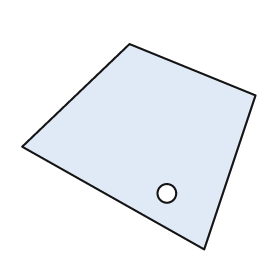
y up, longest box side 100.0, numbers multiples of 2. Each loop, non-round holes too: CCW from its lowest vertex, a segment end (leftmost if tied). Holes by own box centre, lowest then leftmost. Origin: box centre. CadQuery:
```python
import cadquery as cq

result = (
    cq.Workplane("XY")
    .moveTo(28.0, -44.0)
    .lineTo(50.0, 22.0)
    .lineTo(-4.0, 44.0)
    .lineTo(-50.0, 0.0)
    .close()
    .moveTo(12.0, -20.0)
    .circle(4.0)
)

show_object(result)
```